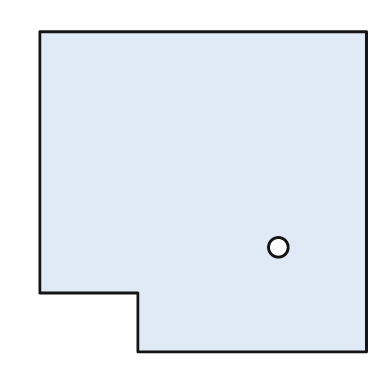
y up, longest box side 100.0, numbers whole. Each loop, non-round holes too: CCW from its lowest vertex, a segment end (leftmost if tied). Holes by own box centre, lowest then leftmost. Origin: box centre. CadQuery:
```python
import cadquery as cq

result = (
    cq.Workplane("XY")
    .moveTo(-20.0, -49.0)
    .lineTo(50.0, -49.0)
    .lineTo(50.0, 49.0)
    .lineTo(-50.0, 49.0)
    .lineTo(-50.0, -31.0)
    .lineTo(-20.0, -31.0)
    .close()
    .moveTo(23.0, -17.0)
    .circle(3.0)
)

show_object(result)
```